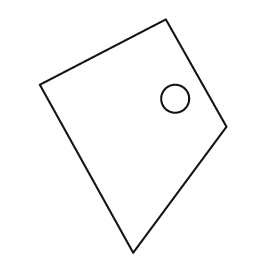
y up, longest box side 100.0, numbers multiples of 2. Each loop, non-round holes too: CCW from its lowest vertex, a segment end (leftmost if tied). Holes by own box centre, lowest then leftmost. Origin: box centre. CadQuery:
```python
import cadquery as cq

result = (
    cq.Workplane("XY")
    .moveTo(0.0, -50.0)
    .lineTo(40.0, 4.0)
    .lineTo(14.0, 50.0)
    .lineTo(-40.0, 22.0)
    .close()
    .moveTo(18.0, 16.0)
    .circle(6.0)
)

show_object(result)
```